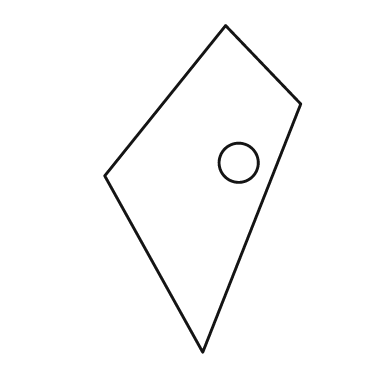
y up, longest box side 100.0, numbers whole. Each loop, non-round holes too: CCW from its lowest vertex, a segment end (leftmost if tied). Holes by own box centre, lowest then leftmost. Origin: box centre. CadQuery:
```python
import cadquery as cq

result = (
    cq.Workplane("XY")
    .moveTo(0.0, -50.0)
    .lineTo(30.0, 26.0)
    .lineTo(7.0, 50.0)
    .lineTo(-30.0, 4.0)
    .close()
    .moveTo(11.0, 8.0)
    .circle(6.0)
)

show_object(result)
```